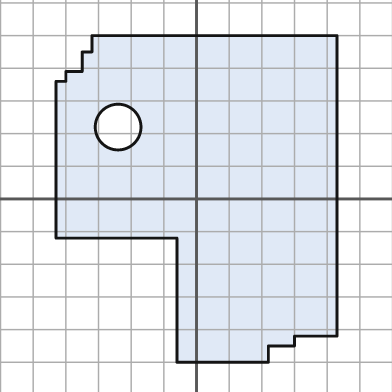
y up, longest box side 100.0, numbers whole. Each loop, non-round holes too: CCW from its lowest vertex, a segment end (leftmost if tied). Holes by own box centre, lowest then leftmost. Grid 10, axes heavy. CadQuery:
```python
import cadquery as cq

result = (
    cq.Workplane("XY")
    .moveTo(-6.0, -50.0)
    .lineTo(22.0, -50.0)
    .lineTo(22.0, -45.0)
    .lineTo(30.0, -45.0)
    .lineTo(30.0, -42.0)
    .lineTo(43.0, -42.0)
    .lineTo(43.0, 50.0)
    .lineTo(-32.0, 50.0)
    .lineTo(-32.0, 45.0)
    .lineTo(-35.0, 45.0)
    .lineTo(-35.0, 39.0)
    .lineTo(-40.0, 39.0)
    .lineTo(-40.0, 36.0)
    .lineTo(-43.0, 36.0)
    .lineTo(-43.0, -12.0)
    .lineTo(-6.0, -12.0)
    .close()
    .moveTo(-24.0, 22.0)
    .circle(7.0)
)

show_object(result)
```